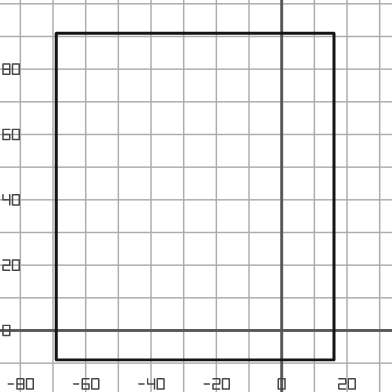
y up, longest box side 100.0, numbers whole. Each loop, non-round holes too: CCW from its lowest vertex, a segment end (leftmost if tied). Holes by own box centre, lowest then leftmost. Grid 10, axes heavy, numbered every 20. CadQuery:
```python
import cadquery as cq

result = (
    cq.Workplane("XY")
    .moveTo(-69.0, -9.0)
    .lineTo(16.0, -9.0)
    .lineTo(16.0, 91.0)
    .lineTo(-69.0, 91.0)
    .close()
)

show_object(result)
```